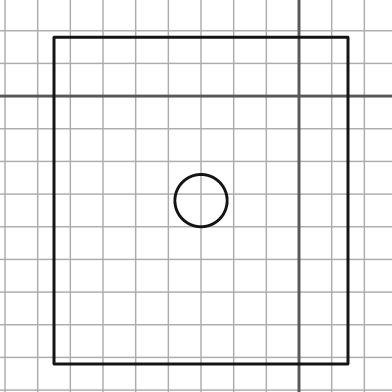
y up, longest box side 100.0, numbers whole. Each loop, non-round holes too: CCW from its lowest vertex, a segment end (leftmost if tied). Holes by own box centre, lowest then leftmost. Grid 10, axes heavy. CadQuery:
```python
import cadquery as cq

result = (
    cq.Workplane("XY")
    .moveTo(-75.0, -82.0)
    .lineTo(15.0, -82.0)
    .lineTo(15.0, 18.0)
    .lineTo(-75.0, 18.0)
    .close()
    .moveTo(-30.0, -32.0)
    .circle(8.0)
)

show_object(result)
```